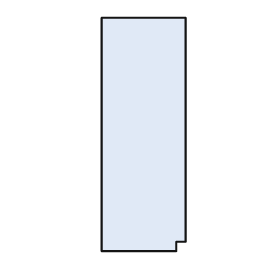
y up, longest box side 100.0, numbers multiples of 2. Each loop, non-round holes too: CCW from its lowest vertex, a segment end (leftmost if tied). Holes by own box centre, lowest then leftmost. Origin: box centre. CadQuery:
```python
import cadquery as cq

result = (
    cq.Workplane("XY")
    .moveTo(-18.0, -50.0)
    .lineTo(14.0, -50.0)
    .lineTo(14.0, -46.0)
    .lineTo(18.0, -46.0)
    .lineTo(18.0, 50.0)
    .lineTo(-18.0, 50.0)
    .close()
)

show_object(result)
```